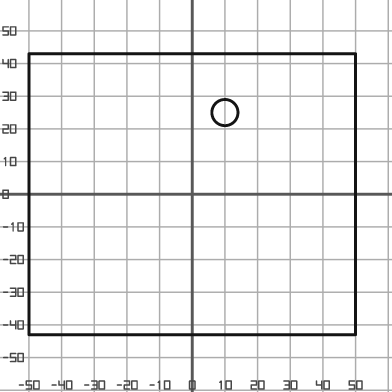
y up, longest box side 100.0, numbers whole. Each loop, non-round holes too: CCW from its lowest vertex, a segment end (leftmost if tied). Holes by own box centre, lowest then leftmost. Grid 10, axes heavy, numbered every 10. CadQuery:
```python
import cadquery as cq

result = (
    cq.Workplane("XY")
    .moveTo(-50.0, -43.0)
    .lineTo(50.0, -43.0)
    .lineTo(50.0, 43.0)
    .lineTo(-50.0, 43.0)
    .close()
    .moveTo(10.0, 25.0)
    .circle(4.0)
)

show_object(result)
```